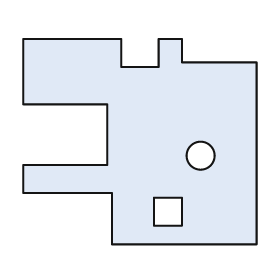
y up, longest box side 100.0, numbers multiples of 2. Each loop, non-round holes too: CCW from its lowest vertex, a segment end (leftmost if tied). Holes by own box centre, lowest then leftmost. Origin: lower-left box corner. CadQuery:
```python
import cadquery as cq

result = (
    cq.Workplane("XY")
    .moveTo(38.0, 0.0)
    .lineTo(100.0, 0.0)
    .lineTo(100.0, 78.0)
    .lineTo(68.0, 78.0)
    .lineTo(68.0, 88.0)
    .lineTo(58.0, 88.0)
    .lineTo(58.0, 76.0)
    .lineTo(42.0, 76.0)
    .lineTo(42.0, 88.0)
    .lineTo(0.0, 88.0)
    .lineTo(0.0, 60.0)
    .lineTo(36.0, 60.0)
    .lineTo(36.0, 34.0)
    .lineTo(0.0, 34.0)
    .lineTo(0.0, 22.0)
    .lineTo(38.0, 22.0)
    .close()
    .moveTo(56.0, 8.0)
    .lineTo(68.0, 8.0)
    .lineTo(68.0, 20.0)
    .lineTo(56.0, 20.0)
    .close()
    .moveTo(76.0, 38.0)
    .circle(6.0)
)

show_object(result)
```